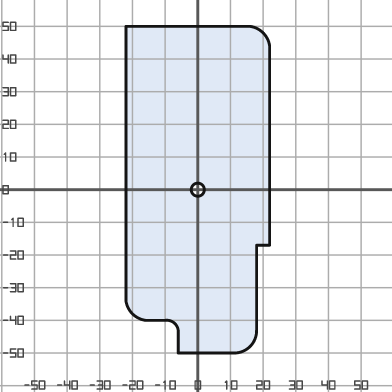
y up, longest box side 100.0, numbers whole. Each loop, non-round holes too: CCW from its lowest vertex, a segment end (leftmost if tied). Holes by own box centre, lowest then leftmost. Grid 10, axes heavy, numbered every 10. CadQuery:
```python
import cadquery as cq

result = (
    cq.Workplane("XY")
    .moveTo(-6.0, -50.0)
    .lineTo(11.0, -50.0)
    .threePointArc((16.0, -48.0), (18.0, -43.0))
    .lineTo(18.0, -17.0)
    .lineTo(22.0, -17.0)
    .lineTo(22.0, 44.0)
    .threePointArc((20.0, 48.0), (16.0, 50.0))
    .lineTo(-22.0, 50.0)
    .lineTo(-22.0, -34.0)
    .threePointArc((-20.0, -38.0), (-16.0, -40.0))
    .lineTo(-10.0, -40.0)
    .threePointArc((-7.0, -41.0), (-6.0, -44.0))
    .close()
    .moveTo(0.0, 0.0)
    .circle(2.0)
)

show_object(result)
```